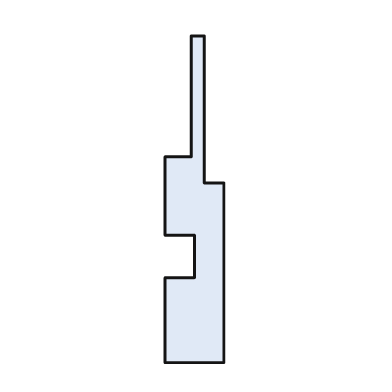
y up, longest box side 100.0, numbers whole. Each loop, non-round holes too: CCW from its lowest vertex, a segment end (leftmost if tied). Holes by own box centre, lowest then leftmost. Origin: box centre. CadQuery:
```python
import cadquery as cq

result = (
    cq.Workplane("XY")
    .moveTo(-9.0, -50.0)
    .lineTo(9.0, -50.0)
    .lineTo(9.0, 5.0)
    .lineTo(3.0, 5.0)
    .lineTo(3.0, 50.0)
    .lineTo(-1.0, 50.0)
    .lineTo(-1.0, 13.0)
    .lineTo(-9.0, 13.0)
    .lineTo(-9.0, -11.0)
    .lineTo(0.0, -11.0)
    .lineTo(0.0, -24.0)
    .lineTo(-9.0, -24.0)
    .close()
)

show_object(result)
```